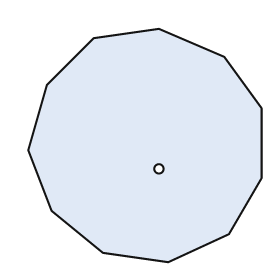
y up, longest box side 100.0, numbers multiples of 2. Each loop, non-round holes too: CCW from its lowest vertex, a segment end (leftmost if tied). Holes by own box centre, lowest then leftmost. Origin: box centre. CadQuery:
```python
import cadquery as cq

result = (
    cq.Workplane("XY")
    .moveTo(10.0, -50.0)
    .lineTo(36.0, -38.0)
    .lineTo(50.0, -14.0)
    .lineTo(50.0, 16.0)
    .lineTo(34.0, 38.0)
    .lineTo(6.0, 50.0)
    .lineTo(-22.0, 46.0)
    .lineTo(-42.0, 26.0)
    .lineTo(-50.0, -2.0)
    .lineTo(-40.0, -28.0)
    .lineTo(-18.0, -46.0)
    .close()
    .moveTo(6.0, -10.0)
    .circle(2.0)
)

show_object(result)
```